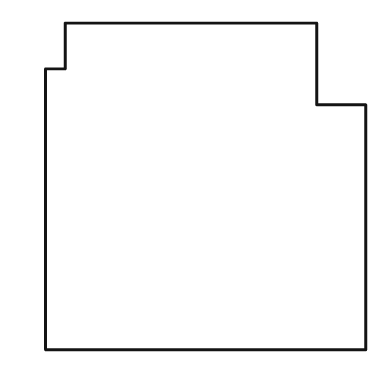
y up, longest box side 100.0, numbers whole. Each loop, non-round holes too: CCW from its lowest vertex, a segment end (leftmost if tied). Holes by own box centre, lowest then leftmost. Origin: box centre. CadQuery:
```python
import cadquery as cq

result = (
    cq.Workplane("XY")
    .moveTo(-49.0, -50.0)
    .lineTo(49.0, -50.0)
    .lineTo(49.0, 25.0)
    .lineTo(34.0, 25.0)
    .lineTo(34.0, 50.0)
    .lineTo(-43.0, 50.0)
    .lineTo(-43.0, 36.0)
    .lineTo(-49.0, 36.0)
    .close()
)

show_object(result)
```